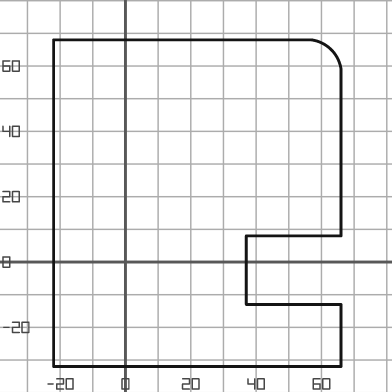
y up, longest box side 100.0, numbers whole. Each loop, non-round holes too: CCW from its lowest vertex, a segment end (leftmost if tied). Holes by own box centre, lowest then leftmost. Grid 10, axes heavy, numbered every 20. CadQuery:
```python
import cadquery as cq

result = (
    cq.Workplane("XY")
    .moveTo(-22.0, -32.0)
    .lineTo(66.0, -32.0)
    .lineTo(66.0, -13.0)
    .lineTo(37.0, -13.0)
    .lineTo(37.0, 8.0)
    .lineTo(66.0, 8.0)
    .lineTo(66.0, 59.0)
    .threePointArc((63.0, 65.0), (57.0, 68.0))
    .lineTo(-22.0, 68.0)
    .close()
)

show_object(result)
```